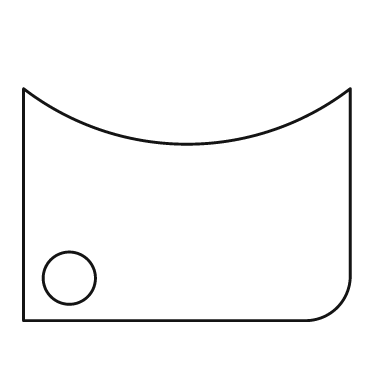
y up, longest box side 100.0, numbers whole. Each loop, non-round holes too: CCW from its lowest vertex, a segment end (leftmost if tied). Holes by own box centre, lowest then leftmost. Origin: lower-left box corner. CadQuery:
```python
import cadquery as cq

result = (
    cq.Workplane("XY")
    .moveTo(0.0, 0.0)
    .lineTo(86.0, 0.0)
    .threePointArc((96.0, 4.0), (100.0, 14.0))
    .lineTo(100.0, 71.0)
    .threePointArc((50.0, 54.0), (0.0, 71.0))
    .close()
    .moveTo(14.0, 13.0)
    .circle(8.0)
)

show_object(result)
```